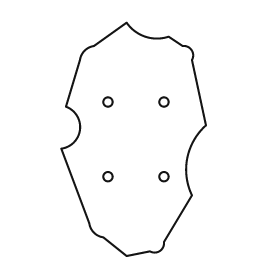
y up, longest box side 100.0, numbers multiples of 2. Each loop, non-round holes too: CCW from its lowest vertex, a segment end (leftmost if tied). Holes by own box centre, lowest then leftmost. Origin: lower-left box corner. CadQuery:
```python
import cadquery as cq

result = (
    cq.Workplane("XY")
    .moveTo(28.0, 0.0)
    .lineTo(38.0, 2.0)
    .threePointArc((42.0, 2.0), (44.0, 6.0))
    .lineTo(56.0, 26.0)
    .threePointArc((54.0, 42.0), (62.0, 56.0))
    .lineTo(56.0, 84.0)
    .threePointArc((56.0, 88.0), (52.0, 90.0))
    .lineTo(46.0, 94.0)
    .threePointArc((36.0, 94.0), (28.0, 100.0))
    .lineTo(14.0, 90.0)
    .threePointArc((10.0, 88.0), (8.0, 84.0))
    .lineTo(2.0, 64.0)
    .threePointArc((8.0, 54.0), (0.0, 46.0))
    .lineTo(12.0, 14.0)
    .threePointArc((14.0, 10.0), (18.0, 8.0))
    .close()
    .moveTo(20.0, 34.0)
    .circle(2.0)
    .moveTo(44.0, 34.0)
    .circle(2.0)
    .moveTo(20.0, 66.0)
    .circle(2.0)
    .moveTo(44.0, 66.0)
    .circle(2.0)
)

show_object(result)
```